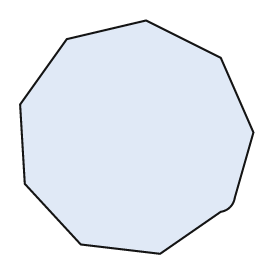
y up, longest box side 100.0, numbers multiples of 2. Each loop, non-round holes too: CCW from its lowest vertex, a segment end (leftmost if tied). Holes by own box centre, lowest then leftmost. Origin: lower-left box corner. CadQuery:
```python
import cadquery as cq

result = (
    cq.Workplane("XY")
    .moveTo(60.0, 0.0)
    .lineTo(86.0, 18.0)
    .threePointArc((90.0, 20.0), (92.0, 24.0))
    .lineTo(100.0, 52.0)
    .lineTo(86.0, 84.0)
    .lineTo(54.0, 100.0)
    .lineTo(20.0, 92.0)
    .lineTo(0.0, 64.0)
    .lineTo(2.0, 30.0)
    .lineTo(26.0, 4.0)
    .close()
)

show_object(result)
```